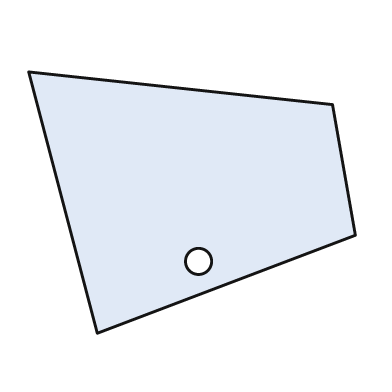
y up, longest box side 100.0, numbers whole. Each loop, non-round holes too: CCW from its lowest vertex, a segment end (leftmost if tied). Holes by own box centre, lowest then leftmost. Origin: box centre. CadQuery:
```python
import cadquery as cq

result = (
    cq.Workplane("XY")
    .moveTo(-29.0, -40.0)
    .lineTo(50.0, -10.0)
    .lineTo(43.0, 30.0)
    .lineTo(-50.0, 40.0)
    .close()
    .moveTo(2.0, -18.0)
    .circle(4.0)
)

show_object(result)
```